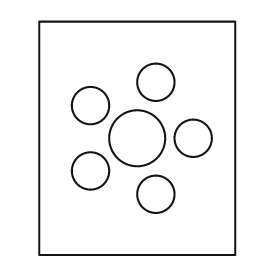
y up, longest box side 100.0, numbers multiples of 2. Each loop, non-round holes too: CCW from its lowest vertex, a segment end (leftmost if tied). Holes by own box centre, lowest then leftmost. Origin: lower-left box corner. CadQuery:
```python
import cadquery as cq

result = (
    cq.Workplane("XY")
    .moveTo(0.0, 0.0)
    .lineTo(84.0, 0.0)
    .lineTo(84.0, 100.0)
    .lineTo(0.0, 100.0)
    .close()
    .moveTo(50.0, 26.0)
    .circle(8.0)
    .moveTo(22.0, 36.0)
    .circle(8.0)
    .moveTo(42.0, 50.0)
    .circle(12.0)
    .moveTo(66.0, 50.0)
    .circle(8.0)
    .moveTo(22.0, 64.0)
    .circle(8.0)
    .moveTo(50.0, 74.0)
    .circle(8.0)
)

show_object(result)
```